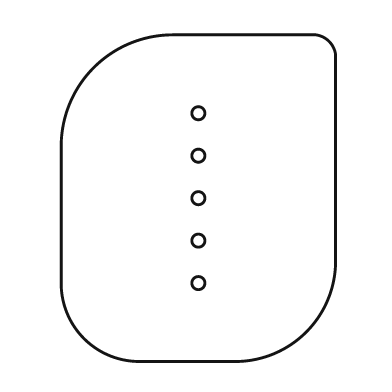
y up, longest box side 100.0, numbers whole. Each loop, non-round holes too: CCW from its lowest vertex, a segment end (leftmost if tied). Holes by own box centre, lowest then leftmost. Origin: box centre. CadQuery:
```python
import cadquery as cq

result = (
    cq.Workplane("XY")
    .moveTo(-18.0, -50.0)
    .lineTo(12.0, -50.0)
    .threePointArc((33.0, -41.0), (42.0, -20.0))
    .lineTo(42.0, 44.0)
    .threePointArc((40.0, 48.0), (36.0, 50.0))
    .lineTo(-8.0, 50.0)
    .threePointArc((-32.0, 40.0), (-42.0, 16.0))
    .lineTo(-42.0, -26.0)
    .threePointArc((-35.0, -43.0), (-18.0, -50.0))
    .close()
    .moveTo(0.0, -26.0)
    .circle(2.0)
    .moveTo(0.0, -13.0)
    .circle(2.0)
    .moveTo(0.0, 0.0)
    .circle(2.0)
    .moveTo(0.0, 13.0)
    .circle(2.0)
    .moveTo(0.0, 26.0)
    .circle(2.0)
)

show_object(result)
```